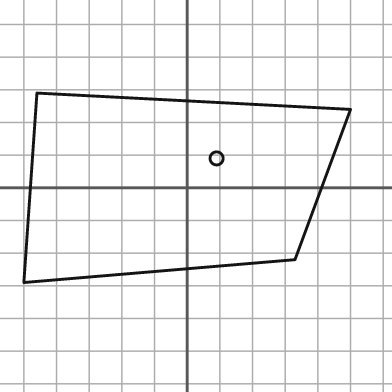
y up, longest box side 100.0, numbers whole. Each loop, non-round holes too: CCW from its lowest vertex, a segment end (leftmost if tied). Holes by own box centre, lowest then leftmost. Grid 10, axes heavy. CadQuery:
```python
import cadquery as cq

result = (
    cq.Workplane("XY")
    .moveTo(-50.0, -29.0)
    .lineTo(33.0, -22.0)
    .lineTo(50.0, 24.0)
    .lineTo(-46.0, 29.0)
    .close()
    .moveTo(9.0, 9.0)
    .circle(2.0)
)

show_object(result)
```